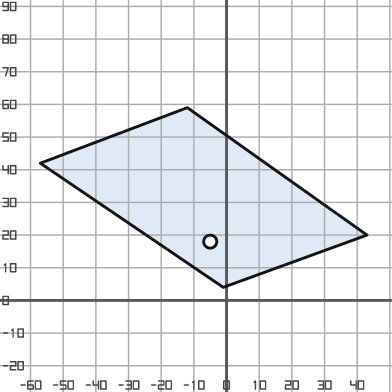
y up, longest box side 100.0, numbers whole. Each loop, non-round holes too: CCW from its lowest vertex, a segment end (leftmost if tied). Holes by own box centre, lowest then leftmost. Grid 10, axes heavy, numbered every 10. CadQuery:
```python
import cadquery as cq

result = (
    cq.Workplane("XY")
    .moveTo(-1.0, 4.0)
    .lineTo(43.0, 20.0)
    .lineTo(-12.0, 59.0)
    .lineTo(-57.0, 42.0)
    .close()
    .moveTo(-5.0, 18.0)
    .circle(2.0)
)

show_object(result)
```